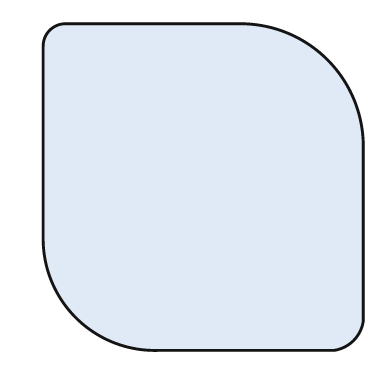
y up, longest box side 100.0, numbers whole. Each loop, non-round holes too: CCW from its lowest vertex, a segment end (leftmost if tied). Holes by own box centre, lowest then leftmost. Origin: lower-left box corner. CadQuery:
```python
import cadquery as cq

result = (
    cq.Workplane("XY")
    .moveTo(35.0, 0.0)
    .lineTo(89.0, 0.0)
    .threePointArc((95.0, 3.0), (98.0, 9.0))
    .lineTo(98.0, 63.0)
    .threePointArc((87.0, 89.0), (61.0, 100.0))
    .lineTo(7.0, 100.0)
    .threePointArc((2.0, 98.0), (0.0, 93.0))
    .lineTo(0.0, 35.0)
    .threePointArc((10.0, 10.0), (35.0, 0.0))
    .close()
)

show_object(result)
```